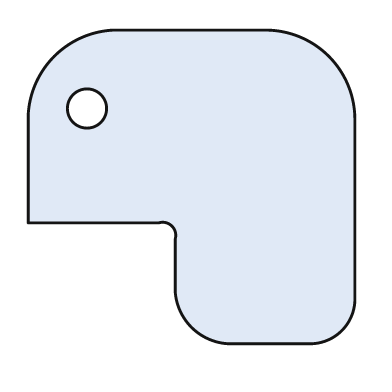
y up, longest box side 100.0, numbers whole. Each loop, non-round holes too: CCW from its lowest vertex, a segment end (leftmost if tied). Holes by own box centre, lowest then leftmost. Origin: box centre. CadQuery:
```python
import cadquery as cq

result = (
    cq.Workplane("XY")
    .moveTo(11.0, -48.0)
    .lineTo(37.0, -48.0)
    .threePointArc((46.0, -44.0), (50.0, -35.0))
    .lineTo(50.0, 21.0)
    .threePointArc((42.0, 40.0), (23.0, 48.0))
    .lineTo(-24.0, 48.0)
    .threePointArc((-42.0, 40.0), (-50.0, 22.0))
    .lineTo(-50.0, -11.0)
    .lineTo(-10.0, -11.0)
    .threePointArc((-6.0, -12.0), (-5.0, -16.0))
    .lineTo(-5.0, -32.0)
    .threePointArc((0.0, -43.0), (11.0, -48.0))
    .close()
    .moveTo(-32.0, 24.0)
    .circle(6.0)
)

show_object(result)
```